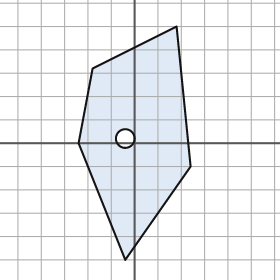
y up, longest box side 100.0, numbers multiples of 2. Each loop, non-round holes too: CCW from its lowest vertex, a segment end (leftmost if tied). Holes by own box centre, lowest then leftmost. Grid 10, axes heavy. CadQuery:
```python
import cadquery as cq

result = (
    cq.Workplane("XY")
    .moveTo(-4.0, -50.0)
    .lineTo(24.0, -10.0)
    .lineTo(18.0, 50.0)
    .lineTo(-18.0, 32.0)
    .lineTo(-24.0, 0.0)
    .close()
    .moveTo(-4.0, 2.0)
    .circle(4.0)
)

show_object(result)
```